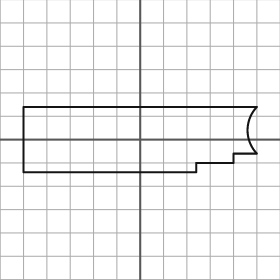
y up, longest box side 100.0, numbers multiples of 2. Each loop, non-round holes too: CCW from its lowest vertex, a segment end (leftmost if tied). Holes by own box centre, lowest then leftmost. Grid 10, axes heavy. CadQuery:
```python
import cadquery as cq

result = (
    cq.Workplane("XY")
    .moveTo(-50.0, -14.0)
    .lineTo(24.0, -14.0)
    .lineTo(24.0, -10.0)
    .lineTo(40.0, -10.0)
    .lineTo(40.0, -6.0)
    .lineTo(50.0, -6.0)
    .threePointArc((46.0, 4.0), (50.0, 14.0))
    .lineTo(-50.0, 14.0)
    .close()
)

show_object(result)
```